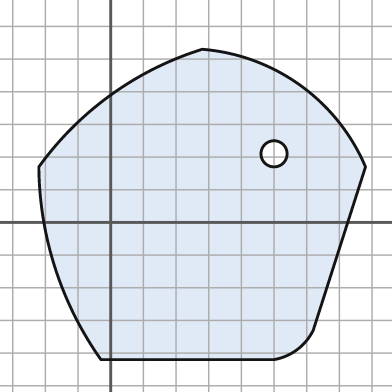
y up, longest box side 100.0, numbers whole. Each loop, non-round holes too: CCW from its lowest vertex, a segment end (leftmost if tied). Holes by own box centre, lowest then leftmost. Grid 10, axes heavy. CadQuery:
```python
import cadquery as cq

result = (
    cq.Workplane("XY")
    .moveTo(-3.0, -42.0)
    .lineTo(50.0, -42.0)
    .threePointArc((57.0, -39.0), (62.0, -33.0))
    .lineTo(78.0, 17.0)
    .threePointArc((58.0, 42.0), (28.0, 53.0))
    .threePointArc((0.0, 39.0), (-22.0, 17.0))
    .threePointArc((-17.0, -14.0), (-3.0, -42.0))
    .close()
    .moveTo(50.0, 21.0)
    .circle(4.0)
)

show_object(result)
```